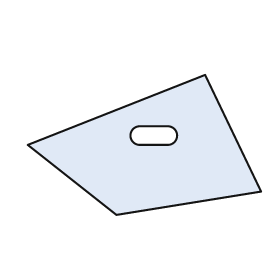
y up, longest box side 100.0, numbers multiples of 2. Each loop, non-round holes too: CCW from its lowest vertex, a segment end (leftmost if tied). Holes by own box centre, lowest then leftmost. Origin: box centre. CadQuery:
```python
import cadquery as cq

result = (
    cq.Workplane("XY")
    .moveTo(-12.0, -30.0)
    .lineTo(50.0, -20.0)
    .lineTo(26.0, 30.0)
    .lineTo(-50.0, 0.0)
    .close()
    .moveTo(-2.0, 0.0)
    .lineTo(10.0, 0.0)
    .threePointArc((14.0, 4.0), (10.0, 8.0))
    .lineTo(-2.0, 8.0)
    .threePointArc((-6.0, 4.0), (-2.0, 0.0))
    .close()
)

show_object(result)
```